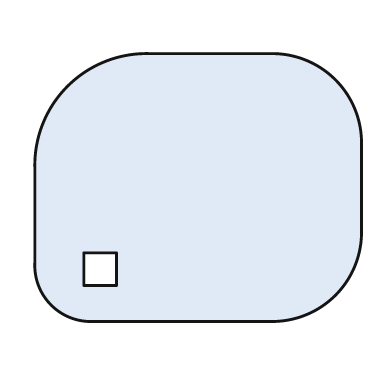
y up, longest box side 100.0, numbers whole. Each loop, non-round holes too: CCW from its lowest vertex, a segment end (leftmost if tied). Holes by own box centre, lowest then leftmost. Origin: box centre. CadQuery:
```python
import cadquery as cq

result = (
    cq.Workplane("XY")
    .moveTo(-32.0, -41.0)
    .lineTo(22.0, -41.0)
    .threePointArc((42.0, -33.0), (50.0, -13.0))
    .lineTo(50.0, 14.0)
    .threePointArc((42.0, 33.0), (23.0, 41.0))
    .lineTo(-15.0, 41.0)
    .threePointArc((-40.0, 31.0), (-50.0, 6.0))
    .lineTo(-50.0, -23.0)
    .threePointArc((-45.0, -36.0), (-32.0, -41.0))
    .close()
    .moveTo(-35.0, -30.0)
    .lineTo(-25.0, -30.0)
    .lineTo(-25.0, -20.0)
    .lineTo(-35.0, -20.0)
    .close()
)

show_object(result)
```